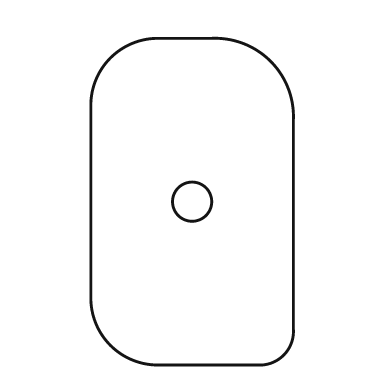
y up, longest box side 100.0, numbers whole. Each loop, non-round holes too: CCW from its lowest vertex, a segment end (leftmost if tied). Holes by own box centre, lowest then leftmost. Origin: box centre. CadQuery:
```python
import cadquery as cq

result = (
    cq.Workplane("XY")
    .moveTo(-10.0, -50.0)
    .lineTo(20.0, -50.0)
    .threePointArc((28.0, -47.0), (31.0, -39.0))
    .lineTo(31.0, 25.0)
    .threePointArc((24.0, 43.0), (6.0, 50.0))
    .lineTo(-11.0, 50.0)
    .threePointArc((-25.0, 44.0), (-31.0, 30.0))
    .lineTo(-31.0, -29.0)
    .threePointArc((-25.0, -44.0), (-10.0, -50.0))
    .close()
    .moveTo(0.0, 0.0)
    .circle(6.0)
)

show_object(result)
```